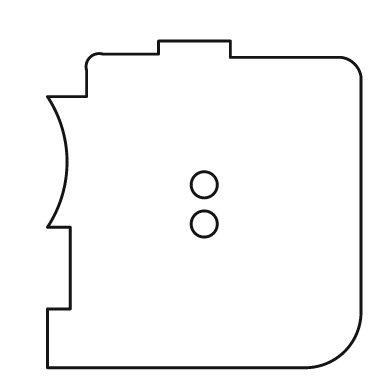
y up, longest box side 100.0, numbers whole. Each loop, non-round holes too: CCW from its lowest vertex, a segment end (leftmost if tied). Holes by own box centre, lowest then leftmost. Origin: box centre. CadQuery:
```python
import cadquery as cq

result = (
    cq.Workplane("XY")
    .moveTo(-48.0, -50.0)
    .lineTo(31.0, -50.0)
    .threePointArc((43.0, -45.0), (48.0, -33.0))
    .lineTo(48.0, 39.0)
    .threePointArc((46.0, 43.0), (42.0, 45.0))
    .lineTo(8.0, 45.0)
    .lineTo(8.0, 50.0)
    .lineTo(-14.0, 50.0)
    .lineTo(-14.0, 46.0)
    .lineTo(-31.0, 46.0)
    .threePointArc((-35.0, 45.0), (-36.0, 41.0))
    .lineTo(-36.0, 33.0)
    .lineTo(-48.0, 33.0)
    .threePointArc((-42.0, 13.0), (-48.0, -7.0))
    .lineTo(-41.0, -7.0)
    .lineTo(-41.0, -32.0)
    .lineTo(-48.0, -32.0)
    .close()
    .moveTo(0.0, -6.0)
    .circle(4.0)
    .moveTo(0.0, 6.0)
    .circle(4.0)
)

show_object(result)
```